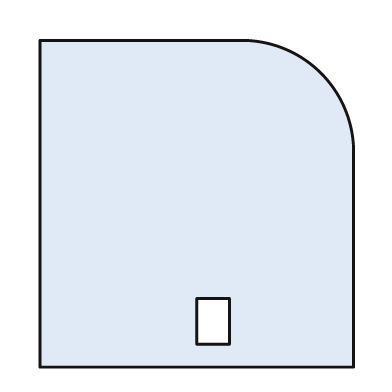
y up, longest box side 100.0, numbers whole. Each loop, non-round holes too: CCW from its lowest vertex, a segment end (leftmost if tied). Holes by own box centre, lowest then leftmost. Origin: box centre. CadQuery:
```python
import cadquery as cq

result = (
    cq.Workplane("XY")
    .moveTo(-48.0, -50.0)
    .lineTo(48.0, -50.0)
    .lineTo(48.0, 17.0)
    .threePointArc((38.0, 40.0), (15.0, 50.0))
    .lineTo(-48.0, 50.0)
    .close()
    .moveTo(0.0, -43.0)
    .lineTo(10.0, -43.0)
    .lineTo(10.0, -29.0)
    .lineTo(0.0, -29.0)
    .close()
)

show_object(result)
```